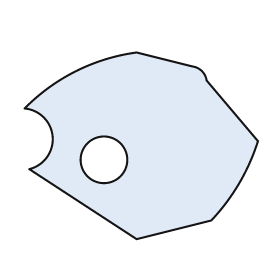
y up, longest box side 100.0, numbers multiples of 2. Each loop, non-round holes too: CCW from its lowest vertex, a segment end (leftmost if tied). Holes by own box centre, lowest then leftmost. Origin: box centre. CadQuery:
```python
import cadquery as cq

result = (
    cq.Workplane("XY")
    .moveTo(-2.0, -40.0)
    .lineTo(30.0, -32.0)
    .threePointArc((42.0, -16.0), (50.0, 2.0))
    .lineTo(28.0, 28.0)
    .threePointArc((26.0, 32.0), (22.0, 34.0))
    .lineTo(-2.0, 40.0)
    .threePointArc((-28.0, 32.0), (-50.0, 16.0))
    .threePointArc((-38.0, 4.0), (-48.0, -10.0))
    .close()
    .moveTo(-16.0, -6.0)
    .circle(10.0)
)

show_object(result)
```